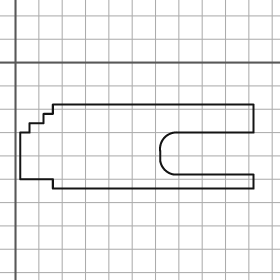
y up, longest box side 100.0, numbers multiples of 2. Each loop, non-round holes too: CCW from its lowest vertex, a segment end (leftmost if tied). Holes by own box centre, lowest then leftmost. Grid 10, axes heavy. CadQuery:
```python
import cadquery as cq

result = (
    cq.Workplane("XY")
    .moveTo(16.0, -54.0)
    .lineTo(102.0, -54.0)
    .lineTo(102.0, -48.0)
    .lineTo(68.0, -48.0)
    .threePointArc((64.0, -46.0), (62.0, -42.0))
    .lineTo(62.0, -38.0)
    .threePointArc((64.0, -32.0), (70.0, -30.0))
    .lineTo(102.0, -30.0)
    .lineTo(102.0, -18.0)
    .lineTo(16.0, -18.0)
    .lineTo(16.0, -22.0)
    .lineTo(12.0, -22.0)
    .lineTo(12.0, -26.0)
    .lineTo(6.0, -26.0)
    .lineTo(6.0, -30.0)
    .lineTo(2.0, -30.0)
    .lineTo(2.0, -50.0)
    .lineTo(16.0, -50.0)
    .close()
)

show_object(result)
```